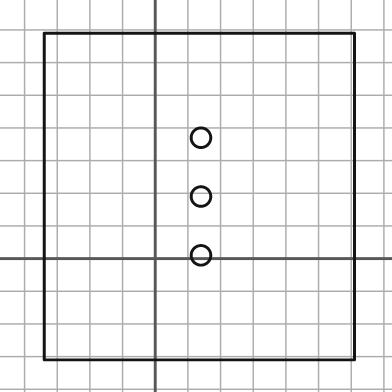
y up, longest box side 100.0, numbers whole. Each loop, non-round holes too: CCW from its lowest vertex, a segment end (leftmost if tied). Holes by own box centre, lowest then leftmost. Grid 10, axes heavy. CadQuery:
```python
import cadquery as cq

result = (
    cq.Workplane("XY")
    .moveTo(-34.0, -31.0)
    .lineTo(61.0, -31.0)
    .lineTo(61.0, 69.0)
    .lineTo(-34.0, 69.0)
    .close()
    .moveTo(14.0, 1.0)
    .circle(3.0)
    .moveTo(14.0, 19.0)
    .circle(3.0)
    .moveTo(14.0, 37.0)
    .circle(3.0)
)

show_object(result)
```